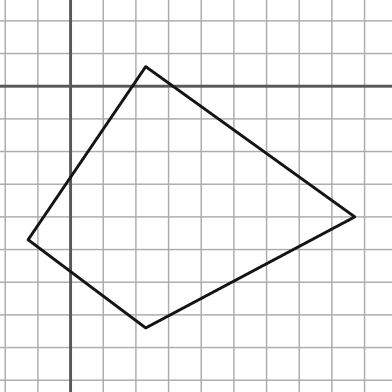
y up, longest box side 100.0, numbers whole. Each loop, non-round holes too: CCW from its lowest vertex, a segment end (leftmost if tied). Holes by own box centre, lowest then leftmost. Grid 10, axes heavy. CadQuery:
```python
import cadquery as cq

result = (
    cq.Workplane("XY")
    .moveTo(23.0, -74.0)
    .lineTo(87.0, -40.0)
    .lineTo(23.0, 6.0)
    .lineTo(-13.0, -47.0)
    .close()
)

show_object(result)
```